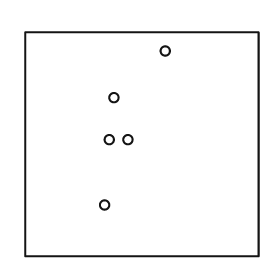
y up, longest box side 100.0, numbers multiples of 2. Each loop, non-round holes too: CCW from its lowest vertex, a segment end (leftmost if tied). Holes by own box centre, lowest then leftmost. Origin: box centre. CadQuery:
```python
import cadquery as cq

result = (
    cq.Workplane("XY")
    .moveTo(-50.0, -48.0)
    .lineTo(50.0, -48.0)
    .lineTo(50.0, 48.0)
    .lineTo(-50.0, 48.0)
    .close()
    .moveTo(-16.0, -26.0)
    .circle(2.0)
    .moveTo(-14.0, 2.0)
    .circle(2.0)
    .moveTo(-6.0, 2.0)
    .circle(2.0)
    .moveTo(-12.0, 20.0)
    .circle(2.0)
    .moveTo(10.0, 40.0)
    .circle(2.0)
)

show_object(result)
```